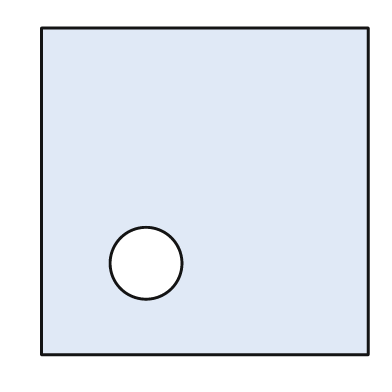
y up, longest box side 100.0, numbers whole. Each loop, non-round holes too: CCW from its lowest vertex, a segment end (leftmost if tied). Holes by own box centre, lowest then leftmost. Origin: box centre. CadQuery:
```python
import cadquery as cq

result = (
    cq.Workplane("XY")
    .moveTo(-50.0, -50.0)
    .lineTo(50.0, -50.0)
    .lineTo(50.0, 50.0)
    .lineTo(-50.0, 50.0)
    .close()
    .moveTo(-18.0, -22.0)
    .circle(11.0)
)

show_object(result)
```